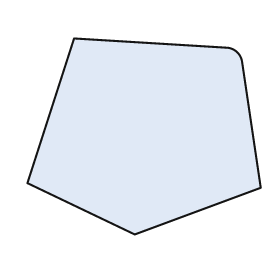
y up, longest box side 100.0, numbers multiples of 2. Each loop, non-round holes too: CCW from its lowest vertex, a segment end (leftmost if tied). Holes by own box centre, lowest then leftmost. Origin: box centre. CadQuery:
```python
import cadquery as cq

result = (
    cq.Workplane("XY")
    .moveTo(-4.0, -42.0)
    .lineTo(50.0, -22.0)
    .lineTo(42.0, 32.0)
    .threePointArc((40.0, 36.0), (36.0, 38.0))
    .lineTo(-30.0, 42.0)
    .lineTo(-50.0, -20.0)
    .close()
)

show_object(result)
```